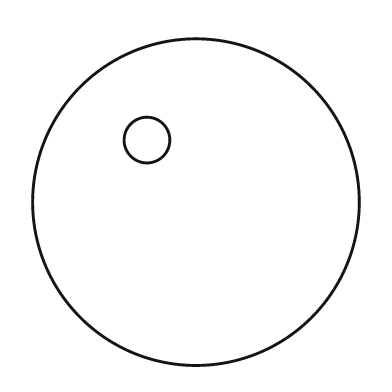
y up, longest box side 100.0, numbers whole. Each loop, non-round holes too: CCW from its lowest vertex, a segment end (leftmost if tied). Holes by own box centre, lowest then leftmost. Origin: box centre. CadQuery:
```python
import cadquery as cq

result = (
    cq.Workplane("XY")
    .moveTo(0.0, 0.0)
    .circle(50.0)
    .moveTo(-15.0, 19.0)
    .circle(7.0)
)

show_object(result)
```